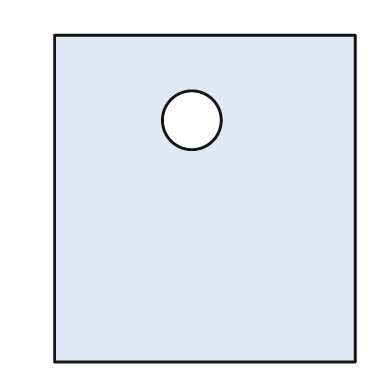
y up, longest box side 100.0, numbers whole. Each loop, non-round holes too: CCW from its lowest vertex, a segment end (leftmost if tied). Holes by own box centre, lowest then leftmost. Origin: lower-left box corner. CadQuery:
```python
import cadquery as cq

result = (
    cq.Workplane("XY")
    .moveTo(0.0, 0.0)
    .lineTo(92.0, 0.0)
    .lineTo(92.0, 100.0)
    .lineTo(0.0, 100.0)
    .close()
    .moveTo(42.0, 74.0)
    .circle(9.0)
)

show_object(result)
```